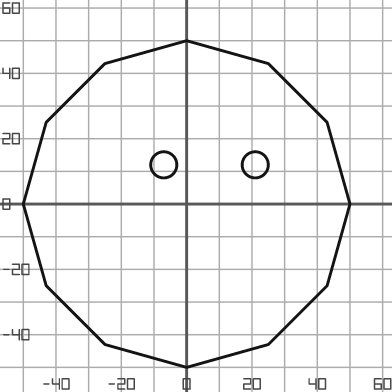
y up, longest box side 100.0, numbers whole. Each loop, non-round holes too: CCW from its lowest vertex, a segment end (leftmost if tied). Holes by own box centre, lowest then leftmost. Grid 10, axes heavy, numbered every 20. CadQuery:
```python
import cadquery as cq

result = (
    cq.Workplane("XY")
    .moveTo(0.0, -50.0)
    .lineTo(25.0, -43.0)
    .lineTo(43.0, -25.0)
    .lineTo(50.0, 0.0)
    .lineTo(43.0, 25.0)
    .lineTo(25.0, 43.0)
    .lineTo(0.0, 50.0)
    .lineTo(-25.0, 43.0)
    .lineTo(-43.0, 25.0)
    .lineTo(-50.0, 0.0)
    .lineTo(-43.0, -25.0)
    .lineTo(-25.0, -43.0)
    .close()
    .moveTo(-7.0, 12.0)
    .circle(4.0)
    .moveTo(21.0, 12.0)
    .circle(4.0)
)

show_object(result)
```